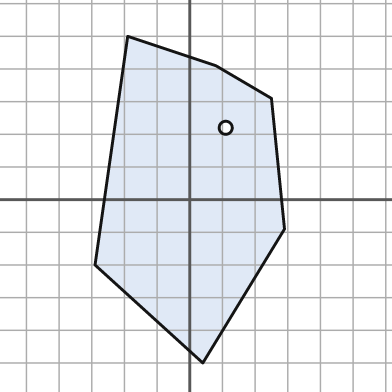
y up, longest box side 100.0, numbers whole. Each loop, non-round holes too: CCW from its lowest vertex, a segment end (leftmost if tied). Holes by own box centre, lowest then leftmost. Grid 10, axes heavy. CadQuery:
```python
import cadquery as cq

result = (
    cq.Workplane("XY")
    .moveTo(4.0, -50.0)
    .lineTo(29.0, -9.0)
    .lineTo(25.0, 31.0)
    .lineTo(8.0, 41.0)
    .lineTo(-19.0, 50.0)
    .lineTo(-29.0, -20.0)
    .close()
    .moveTo(11.0, 22.0)
    .circle(2.0)
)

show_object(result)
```